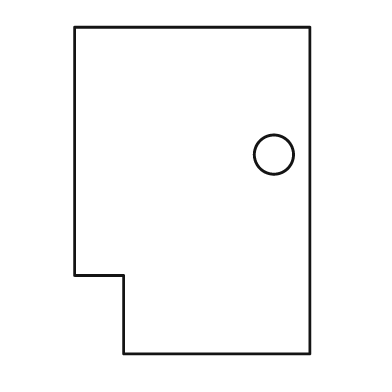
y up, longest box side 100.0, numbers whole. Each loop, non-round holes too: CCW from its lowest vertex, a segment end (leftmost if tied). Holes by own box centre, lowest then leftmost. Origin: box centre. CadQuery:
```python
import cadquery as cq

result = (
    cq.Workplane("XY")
    .moveTo(-21.0, -50.0)
    .lineTo(36.0, -50.0)
    .lineTo(36.0, 50.0)
    .lineTo(-36.0, 50.0)
    .lineTo(-36.0, -26.0)
    .lineTo(-21.0, -26.0)
    .close()
    .moveTo(25.0, 11.0)
    .circle(6.0)
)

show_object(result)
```